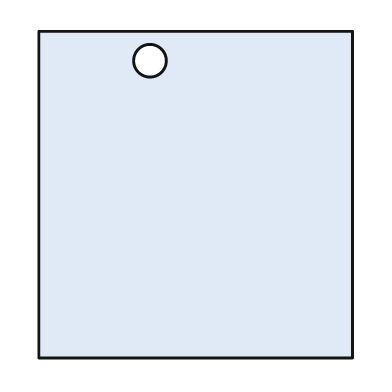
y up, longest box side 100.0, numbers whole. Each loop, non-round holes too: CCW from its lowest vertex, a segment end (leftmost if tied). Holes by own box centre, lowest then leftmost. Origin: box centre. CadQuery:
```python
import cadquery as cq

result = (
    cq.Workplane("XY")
    .moveTo(-48.0, -50.0)
    .lineTo(48.0, -50.0)
    .lineTo(48.0, 50.0)
    .lineTo(-48.0, 50.0)
    .close()
    .moveTo(-14.0, 41.0)
    .circle(5.0)
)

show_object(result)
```